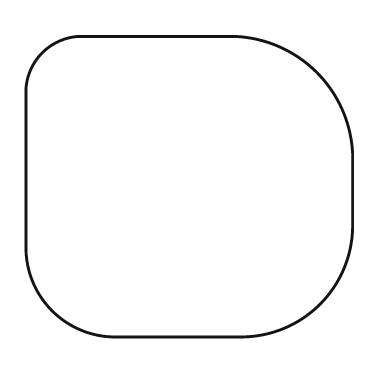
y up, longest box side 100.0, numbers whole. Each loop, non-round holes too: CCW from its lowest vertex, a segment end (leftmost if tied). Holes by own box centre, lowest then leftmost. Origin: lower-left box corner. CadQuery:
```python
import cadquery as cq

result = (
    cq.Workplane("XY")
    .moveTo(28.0, 0.0)
    .lineTo(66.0, 0.0)
    .threePointArc((90.0, 10.0), (100.0, 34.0))
    .lineTo(100.0, 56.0)
    .threePointArc((89.0, 81.0), (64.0, 92.0))
    .lineTo(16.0, 92.0)
    .threePointArc((5.0, 87.0), (0.0, 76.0))
    .lineTo(0.0, 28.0)
    .threePointArc((8.0, 8.0), (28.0, 0.0))
    .close()
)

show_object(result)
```